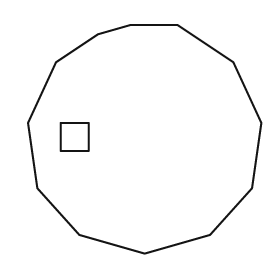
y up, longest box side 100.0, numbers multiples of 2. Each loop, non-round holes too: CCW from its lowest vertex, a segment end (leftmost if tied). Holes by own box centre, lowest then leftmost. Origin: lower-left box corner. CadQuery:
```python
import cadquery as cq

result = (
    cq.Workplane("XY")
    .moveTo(50.0, 0.0)
    .lineTo(78.0, 8.0)
    .lineTo(96.0, 28.0)
    .lineTo(100.0, 56.0)
    .lineTo(88.0, 82.0)
    .lineTo(64.0, 98.0)
    .lineTo(44.0, 98.0)
    .lineTo(30.0, 94.0)
    .lineTo(12.0, 82.0)
    .lineTo(0.0, 56.0)
    .lineTo(4.0, 28.0)
    .lineTo(22.0, 8.0)
    .close()
    .moveTo(14.0, 44.0)
    .lineTo(26.0, 44.0)
    .lineTo(26.0, 56.0)
    .lineTo(14.0, 56.0)
    .close()
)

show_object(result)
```